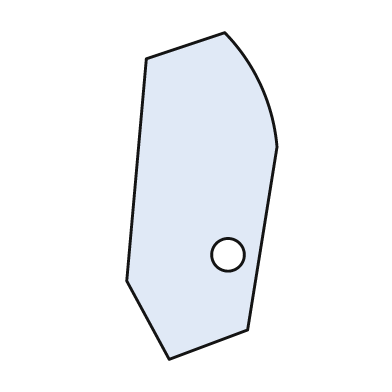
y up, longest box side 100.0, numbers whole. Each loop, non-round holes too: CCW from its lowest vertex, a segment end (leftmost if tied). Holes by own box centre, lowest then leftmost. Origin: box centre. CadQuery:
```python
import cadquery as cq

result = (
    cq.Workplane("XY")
    .moveTo(-10.0, -50.0)
    .lineTo(14.0, -41.0)
    .lineTo(23.0, 15.0)
    .threePointArc((18.0, 34.0), (7.0, 50.0))
    .lineTo(-17.0, 42.0)
    .lineTo(-23.0, -26.0)
    .close()
    .moveTo(8.0, -18.0)
    .circle(5.0)
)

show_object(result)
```